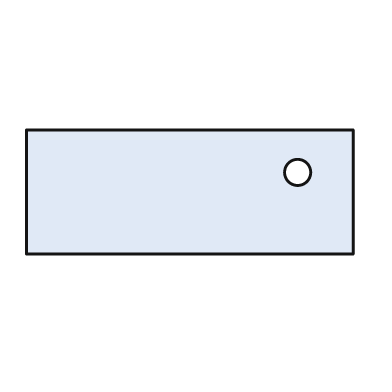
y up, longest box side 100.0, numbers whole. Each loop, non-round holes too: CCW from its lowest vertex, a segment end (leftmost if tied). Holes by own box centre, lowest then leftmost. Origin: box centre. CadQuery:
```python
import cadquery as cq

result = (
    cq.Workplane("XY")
    .moveTo(-50.0, -19.0)
    .lineTo(50.0, -19.0)
    .lineTo(50.0, 19.0)
    .lineTo(-50.0, 19.0)
    .close()
    .moveTo(33.0, 6.0)
    .circle(4.0)
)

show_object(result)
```